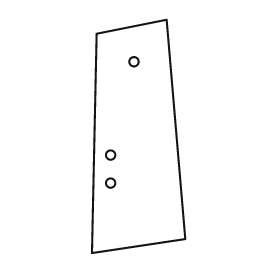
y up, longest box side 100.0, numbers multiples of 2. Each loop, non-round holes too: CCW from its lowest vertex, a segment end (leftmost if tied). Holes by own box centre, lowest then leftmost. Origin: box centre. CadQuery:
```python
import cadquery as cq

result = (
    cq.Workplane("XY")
    .moveTo(-20.0, -50.0)
    .lineTo(20.0, -44.0)
    .lineTo(12.0, 50.0)
    .lineTo(-18.0, 44.0)
    .close()
    .moveTo(-12.0, -20.0)
    .circle(2.0)
    .moveTo(-12.0, -8.0)
    .circle(2.0)
    .moveTo(-2.0, 32.0)
    .circle(2.0)
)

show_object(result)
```